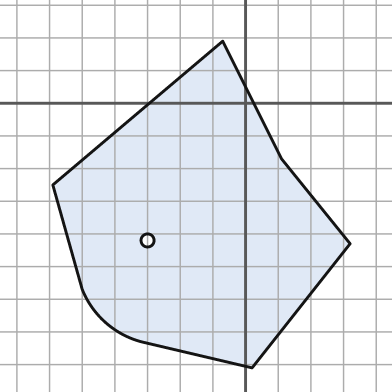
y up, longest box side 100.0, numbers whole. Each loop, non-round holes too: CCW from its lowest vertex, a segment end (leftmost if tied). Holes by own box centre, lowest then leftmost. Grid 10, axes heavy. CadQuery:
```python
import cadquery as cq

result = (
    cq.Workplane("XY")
    .moveTo(2.0, -81.0)
    .lineTo(32.0, -43.0)
    .lineTo(11.0, -17.0)
    .lineTo(-7.0, 19.0)
    .lineTo(-59.0, -25.0)
    .lineTo(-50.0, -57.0)
    .threePointArc((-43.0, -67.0), (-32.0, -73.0))
    .close()
    .moveTo(-30.0, -42.0)
    .circle(2.0)
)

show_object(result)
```